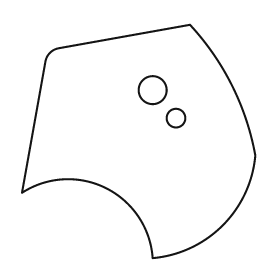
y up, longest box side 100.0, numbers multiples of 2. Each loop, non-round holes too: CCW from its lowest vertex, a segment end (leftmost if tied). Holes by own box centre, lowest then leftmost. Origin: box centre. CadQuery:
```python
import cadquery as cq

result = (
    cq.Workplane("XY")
    .moveTo(6.0, -50.0)
    .threePointArc((36.0, -36.0), (50.0, -6.0))
    .threePointArc((40.0, 24.0), (22.0, 50.0))
    .lineTo(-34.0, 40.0)
    .threePointArc((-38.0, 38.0), (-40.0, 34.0))
    .lineTo(-50.0, -22.0)
    .threePointArc((-14.0, -20.0), (6.0, -50.0))
    .close()
    .moveTo(16.0, 10.0)
    .circle(4.0)
    .moveTo(6.0, 22.0)
    .circle(6.0)
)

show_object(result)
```